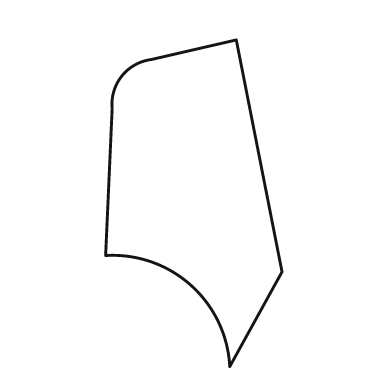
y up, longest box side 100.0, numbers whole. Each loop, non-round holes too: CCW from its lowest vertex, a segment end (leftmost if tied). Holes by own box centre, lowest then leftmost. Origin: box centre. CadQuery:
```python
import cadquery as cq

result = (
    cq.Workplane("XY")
    .moveTo(11.0, -50.0)
    .lineTo(27.0, -21.0)
    .lineTo(13.0, 50.0)
    .lineTo(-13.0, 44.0)
    .threePointArc((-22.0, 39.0), (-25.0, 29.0))
    .lineTo(-27.0, -16.0)
    .threePointArc((-1.0, -25.0), (11.0, -50.0))
    .close()
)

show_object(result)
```